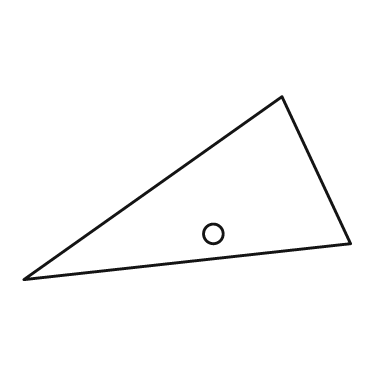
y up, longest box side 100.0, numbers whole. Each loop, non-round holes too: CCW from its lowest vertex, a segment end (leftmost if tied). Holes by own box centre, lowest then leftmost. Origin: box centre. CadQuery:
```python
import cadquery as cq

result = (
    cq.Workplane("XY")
    .moveTo(-50.0, -28.0)
    .lineTo(50.0, -17.0)
    .lineTo(29.0, 28.0)
    .close()
    .moveTo(8.0, -14.0)
    .circle(3.0)
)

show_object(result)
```